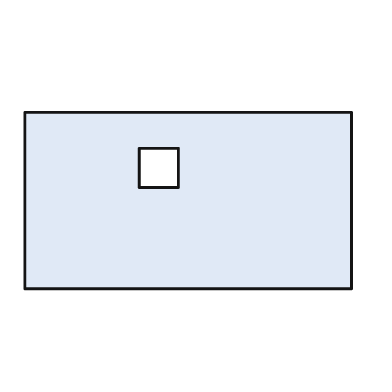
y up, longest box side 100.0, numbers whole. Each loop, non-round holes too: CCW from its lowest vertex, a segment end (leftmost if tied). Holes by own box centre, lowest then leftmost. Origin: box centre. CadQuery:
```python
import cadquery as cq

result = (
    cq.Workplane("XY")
    .moveTo(-50.0, -27.0)
    .lineTo(50.0, -27.0)
    .lineTo(50.0, 27.0)
    .lineTo(-50.0, 27.0)
    .close()
    .moveTo(-15.0, 4.0)
    .lineTo(-3.0, 4.0)
    .lineTo(-3.0, 16.0)
    .lineTo(-15.0, 16.0)
    .close()
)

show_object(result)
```